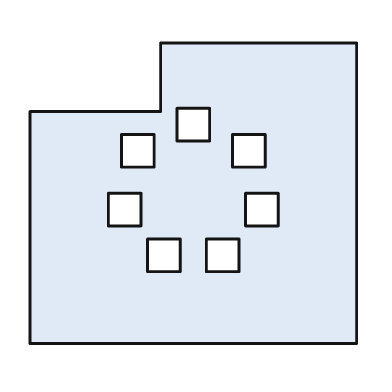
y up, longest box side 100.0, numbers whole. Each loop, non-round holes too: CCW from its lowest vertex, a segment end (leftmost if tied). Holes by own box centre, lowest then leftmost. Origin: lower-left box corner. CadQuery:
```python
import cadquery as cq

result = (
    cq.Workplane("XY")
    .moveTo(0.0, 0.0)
    .lineTo(100.0, 0.0)
    .lineTo(100.0, 92.0)
    .lineTo(40.0, 92.0)
    .lineTo(40.0, 71.0)
    .lineTo(0.0, 71.0)
    .close()
    .moveTo(36.0, 22.0)
    .lineTo(46.0, 22.0)
    .lineTo(46.0, 32.0)
    .lineTo(36.0, 32.0)
    .close()
    .moveTo(54.0, 22.0)
    .lineTo(64.0, 22.0)
    .lineTo(64.0, 32.0)
    .lineTo(54.0, 32.0)
    .close()
    .moveTo(24.0, 36.0)
    .lineTo(34.0, 36.0)
    .lineTo(34.0, 46.0)
    .lineTo(24.0, 46.0)
    .close()
    .moveTo(66.0, 36.0)
    .lineTo(76.0, 36.0)
    .lineTo(76.0, 46.0)
    .lineTo(66.0, 46.0)
    .close()
    .moveTo(28.0, 54.0)
    .lineTo(38.0, 54.0)
    .lineTo(38.0, 64.0)
    .lineTo(28.0, 64.0)
    .close()
    .moveTo(62.0, 54.0)
    .lineTo(72.0, 54.0)
    .lineTo(72.0, 64.0)
    .lineTo(62.0, 64.0)
    .close()
    .moveTo(45.0, 62.0)
    .lineTo(55.0, 62.0)
    .lineTo(55.0, 72.0)
    .lineTo(45.0, 72.0)
    .close()
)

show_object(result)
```